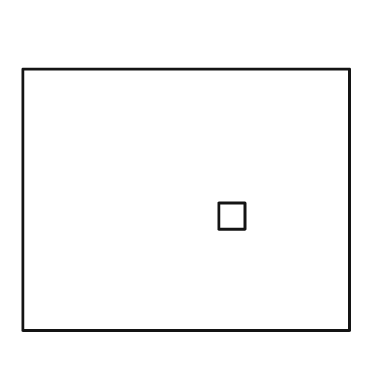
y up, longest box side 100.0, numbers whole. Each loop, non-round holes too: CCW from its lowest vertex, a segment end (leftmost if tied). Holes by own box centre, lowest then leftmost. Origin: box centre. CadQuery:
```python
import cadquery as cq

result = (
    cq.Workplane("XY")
    .moveTo(-50.0, -40.0)
    .lineTo(50.0, -40.0)
    .lineTo(50.0, 40.0)
    .lineTo(-50.0, 40.0)
    .close()
    .moveTo(10.0, -9.0)
    .lineTo(18.0, -9.0)
    .lineTo(18.0, -1.0)
    .lineTo(10.0, -1.0)
    .close()
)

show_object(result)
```